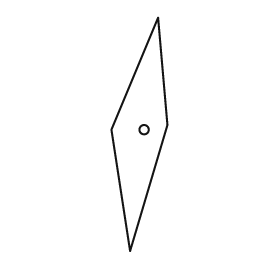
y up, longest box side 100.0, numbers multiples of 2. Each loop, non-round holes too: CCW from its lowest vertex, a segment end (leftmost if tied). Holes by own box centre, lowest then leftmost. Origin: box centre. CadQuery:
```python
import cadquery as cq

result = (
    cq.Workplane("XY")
    .moveTo(-4.0, -50.0)
    .lineTo(12.0, 4.0)
    .lineTo(8.0, 50.0)
    .lineTo(-12.0, 2.0)
    .close()
    .moveTo(2.0, 2.0)
    .circle(2.0)
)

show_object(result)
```